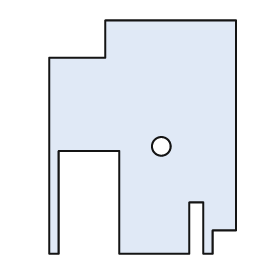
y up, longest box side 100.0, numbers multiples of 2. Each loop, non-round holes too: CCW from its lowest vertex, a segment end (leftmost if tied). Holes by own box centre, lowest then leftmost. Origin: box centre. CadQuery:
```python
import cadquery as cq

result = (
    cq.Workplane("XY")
    .moveTo(-40.0, -50.0)
    .lineTo(-36.0, -50.0)
    .lineTo(-36.0, -6.0)
    .lineTo(-10.0, -6.0)
    .lineTo(-10.0, -50.0)
    .lineTo(20.0, -50.0)
    .lineTo(20.0, -28.0)
    .lineTo(26.0, -28.0)
    .lineTo(26.0, -50.0)
    .lineTo(30.0, -50.0)
    .lineTo(30.0, -40.0)
    .lineTo(40.0, -40.0)
    .lineTo(40.0, 50.0)
    .lineTo(-16.0, 50.0)
    .lineTo(-16.0, 34.0)
    .lineTo(-40.0, 34.0)
    .close()
    .moveTo(8.0, -4.0)
    .circle(4.0)
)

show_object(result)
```